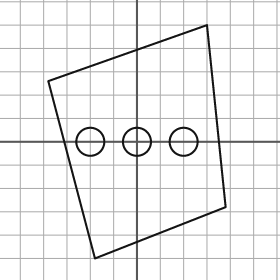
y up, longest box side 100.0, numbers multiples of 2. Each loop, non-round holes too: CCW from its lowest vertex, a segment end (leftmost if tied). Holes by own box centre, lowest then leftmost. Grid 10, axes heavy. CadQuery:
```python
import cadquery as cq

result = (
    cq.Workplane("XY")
    .moveTo(-18.0, -50.0)
    .lineTo(38.0, -28.0)
    .lineTo(30.0, 50.0)
    .lineTo(-38.0, 26.0)
    .close()
    .moveTo(-20.0, 0.0)
    .circle(6.0)
    .moveTo(0.0, 0.0)
    .circle(6.0)
    .moveTo(20.0, 0.0)
    .circle(6.0)
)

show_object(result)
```